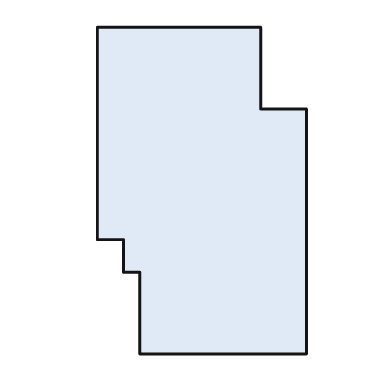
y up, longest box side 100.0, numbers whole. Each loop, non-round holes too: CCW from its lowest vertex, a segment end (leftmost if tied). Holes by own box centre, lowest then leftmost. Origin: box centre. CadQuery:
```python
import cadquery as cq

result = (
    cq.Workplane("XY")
    .moveTo(-19.0, -50.0)
    .lineTo(32.0, -50.0)
    .lineTo(32.0, 25.0)
    .lineTo(18.0, 25.0)
    .lineTo(18.0, 50.0)
    .lineTo(-32.0, 50.0)
    .lineTo(-32.0, -15.0)
    .lineTo(-24.0, -15.0)
    .lineTo(-24.0, -25.0)
    .lineTo(-19.0, -25.0)
    .close()
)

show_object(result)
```